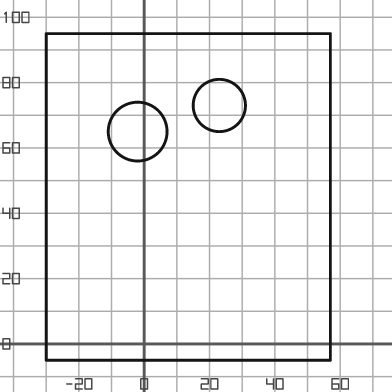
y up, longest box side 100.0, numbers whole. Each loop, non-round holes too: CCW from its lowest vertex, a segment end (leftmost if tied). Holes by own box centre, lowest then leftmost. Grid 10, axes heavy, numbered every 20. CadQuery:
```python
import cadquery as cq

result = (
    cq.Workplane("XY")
    .moveTo(-30.0, -5.0)
    .lineTo(57.0, -5.0)
    .lineTo(57.0, 95.0)
    .lineTo(-30.0, 95.0)
    .close()
    .moveTo(-2.0, 65.0)
    .circle(9.0)
    .moveTo(23.0, 73.0)
    .circle(8.0)
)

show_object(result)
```